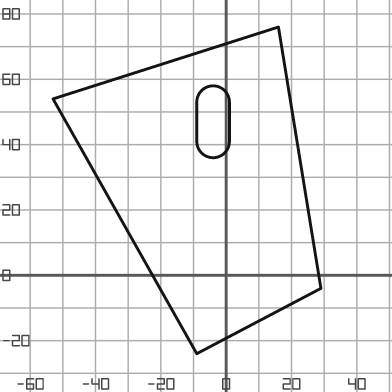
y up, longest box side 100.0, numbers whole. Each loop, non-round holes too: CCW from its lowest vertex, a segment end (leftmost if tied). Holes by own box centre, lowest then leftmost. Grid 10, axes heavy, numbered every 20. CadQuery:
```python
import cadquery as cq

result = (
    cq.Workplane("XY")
    .moveTo(-9.0, -24.0)
    .lineTo(29.0, -4.0)
    .lineTo(16.0, 76.0)
    .lineTo(-53.0, 54.0)
    .close()
    .moveTo(-9.0, 41.0)
    .threePointArc((-4.0, 36.0), (1.0, 41.0))
    .lineTo(1.0, 53.0)
    .threePointArc((-4.0, 58.0), (-9.0, 53.0))
    .close()
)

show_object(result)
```